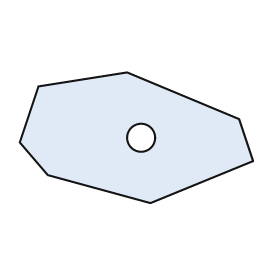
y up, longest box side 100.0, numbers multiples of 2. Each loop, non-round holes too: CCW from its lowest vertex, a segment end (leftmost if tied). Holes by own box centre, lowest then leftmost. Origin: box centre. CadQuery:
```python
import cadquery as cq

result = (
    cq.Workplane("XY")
    .moveTo(6.0, -28.0)
    .lineTo(50.0, -10.0)
    .lineTo(44.0, 8.0)
    .lineTo(-4.0, 28.0)
    .lineTo(-42.0, 22.0)
    .lineTo(-50.0, -2.0)
    .lineTo(-38.0, -16.0)
    .close()
    .moveTo(2.0, 0.0)
    .circle(6.0)
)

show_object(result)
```